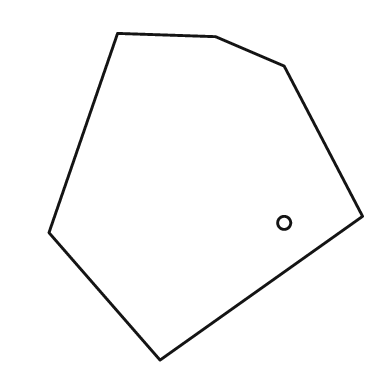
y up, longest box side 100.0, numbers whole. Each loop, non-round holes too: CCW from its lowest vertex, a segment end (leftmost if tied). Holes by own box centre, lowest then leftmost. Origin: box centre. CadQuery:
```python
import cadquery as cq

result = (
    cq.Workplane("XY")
    .moveTo(-14.0, -50.0)
    .lineTo(48.0, -6.0)
    .lineTo(24.0, 40.0)
    .lineTo(3.0, 49.0)
    .lineTo(-27.0, 50.0)
    .lineTo(-48.0, -11.0)
    .close()
    .moveTo(24.0, -8.0)
    .circle(2.0)
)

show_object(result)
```